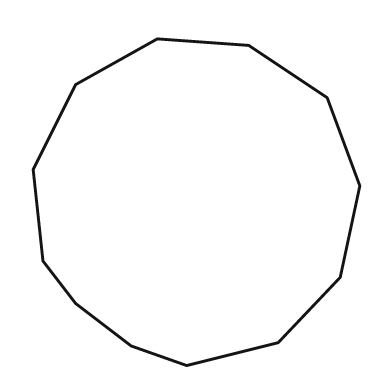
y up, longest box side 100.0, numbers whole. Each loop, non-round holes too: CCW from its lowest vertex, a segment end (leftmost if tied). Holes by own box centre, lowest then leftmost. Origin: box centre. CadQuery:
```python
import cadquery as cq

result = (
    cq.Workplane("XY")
    .moveTo(-3.0, -50.0)
    .lineTo(25.0, -43.0)
    .lineTo(44.0, -23.0)
    .lineTo(50.0, 5.0)
    .lineTo(40.0, 32.0)
    .lineTo(16.0, 48.0)
    .lineTo(-12.0, 50.0)
    .lineTo(-37.0, 36.0)
    .lineTo(-50.0, 10.0)
    .lineTo(-47.0, -18.0)
    .lineTo(-37.0, -31.0)
    .lineTo(-20.0, -44.0)
    .close()
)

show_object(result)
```